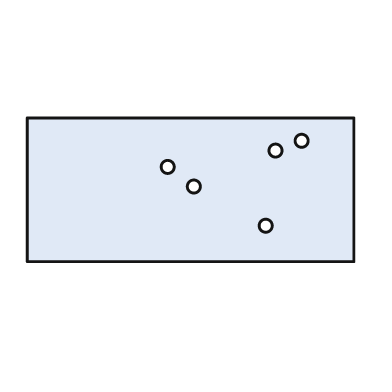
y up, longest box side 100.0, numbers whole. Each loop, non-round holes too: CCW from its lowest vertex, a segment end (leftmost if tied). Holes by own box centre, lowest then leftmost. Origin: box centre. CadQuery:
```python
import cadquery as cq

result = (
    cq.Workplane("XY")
    .moveTo(-50.0, -22.0)
    .lineTo(50.0, -22.0)
    .lineTo(50.0, 22.0)
    .lineTo(-50.0, 22.0)
    .close()
    .moveTo(23.0, -11.0)
    .circle(2.0)
    .moveTo(1.0, 1.0)
    .circle(2.0)
    .moveTo(-7.0, 7.0)
    .circle(2.0)
    .moveTo(26.0, 12.0)
    .circle(2.0)
    .moveTo(34.0, 15.0)
    .circle(2.0)
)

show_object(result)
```